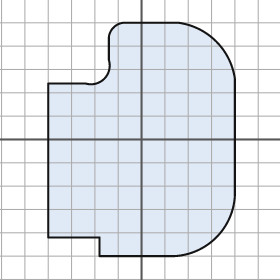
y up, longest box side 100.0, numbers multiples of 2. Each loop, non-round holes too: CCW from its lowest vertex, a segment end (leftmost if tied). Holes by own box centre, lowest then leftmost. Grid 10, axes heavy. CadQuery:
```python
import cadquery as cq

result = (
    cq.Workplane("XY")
    .moveTo(-18.0, -50.0)
    .lineTo(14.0, -50.0)
    .threePointArc((32.0, -42.0), (40.0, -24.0))
    .lineTo(40.0, 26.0)
    .threePointArc((32.0, 42.0), (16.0, 50.0))
    .lineTo(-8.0, 50.0)
    .threePointArc((-12.0, 48.0), (-14.0, 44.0))
    .lineTo(-14.0, 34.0)
    .threePointArc((-16.0, 26.0), (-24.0, 24.0))
    .lineTo(-40.0, 24.0)
    .lineTo(-40.0, -42.0)
    .lineTo(-18.0, -42.0)
    .close()
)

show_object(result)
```